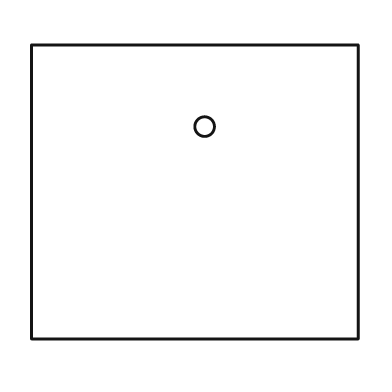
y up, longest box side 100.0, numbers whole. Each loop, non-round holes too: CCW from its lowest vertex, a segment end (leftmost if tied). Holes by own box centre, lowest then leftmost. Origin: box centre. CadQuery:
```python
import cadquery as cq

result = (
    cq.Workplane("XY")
    .moveTo(-50.0, -45.0)
    .lineTo(50.0, -45.0)
    .lineTo(50.0, 45.0)
    .lineTo(-50.0, 45.0)
    .close()
    .moveTo(3.0, 20.0)
    .circle(3.0)
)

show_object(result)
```